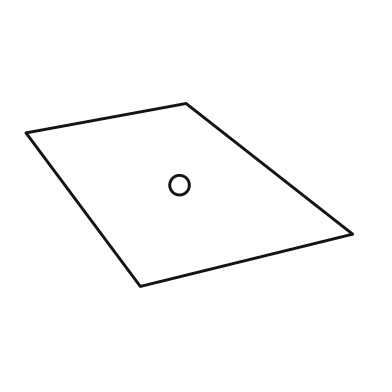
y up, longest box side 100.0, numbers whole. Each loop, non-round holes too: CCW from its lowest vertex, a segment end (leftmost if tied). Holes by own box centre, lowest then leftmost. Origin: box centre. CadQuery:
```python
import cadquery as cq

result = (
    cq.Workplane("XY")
    .moveTo(-15.0, -28.0)
    .lineTo(50.0, -12.0)
    .lineTo(-1.0, 28.0)
    .lineTo(-50.0, 19.0)
    .close()
    .moveTo(-3.0, 3.0)
    .circle(3.0)
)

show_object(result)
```